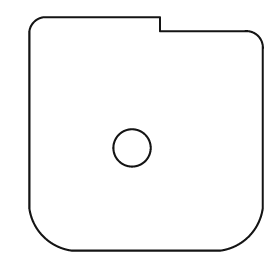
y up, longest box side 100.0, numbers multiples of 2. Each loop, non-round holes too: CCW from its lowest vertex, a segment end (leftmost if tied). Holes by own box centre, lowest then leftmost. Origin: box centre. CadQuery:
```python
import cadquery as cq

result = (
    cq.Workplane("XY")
    .moveTo(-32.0, -50.0)
    .lineTo(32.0, -50.0)
    .threePointArc((44.0, -44.0), (50.0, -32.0))
    .lineTo(50.0, 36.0)
    .threePointArc((48.0, 42.0), (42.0, 44.0))
    .lineTo(6.0, 44.0)
    .lineTo(6.0, 50.0)
    .lineTo(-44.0, 50.0)
    .threePointArc((-48.0, 48.0), (-50.0, 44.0))
    .lineTo(-50.0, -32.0)
    .threePointArc((-44.0, -44.0), (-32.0, -50.0))
    .close()
    .moveTo(-6.0, -6.0)
    .circle(8.0)
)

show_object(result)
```